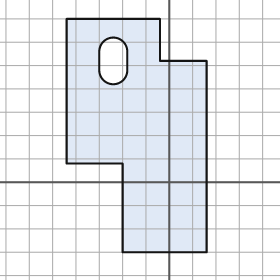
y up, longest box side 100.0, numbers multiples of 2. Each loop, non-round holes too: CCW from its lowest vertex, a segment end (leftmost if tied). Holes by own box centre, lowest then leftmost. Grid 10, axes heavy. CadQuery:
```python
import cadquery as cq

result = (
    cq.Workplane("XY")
    .moveTo(-20.0, -30.0)
    .lineTo(16.0, -30.0)
    .lineTo(16.0, 52.0)
    .lineTo(-4.0, 52.0)
    .lineTo(-4.0, 70.0)
    .lineTo(-44.0, 70.0)
    .lineTo(-44.0, 8.0)
    .lineTo(-20.0, 8.0)
    .close()
    .moveTo(-30.0, 48.0)
    .threePointArc((-24.0, 42.0), (-18.0, 48.0))
    .lineTo(-18.0, 56.0)
    .threePointArc((-24.0, 62.0), (-30.0, 56.0))
    .close()
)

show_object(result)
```